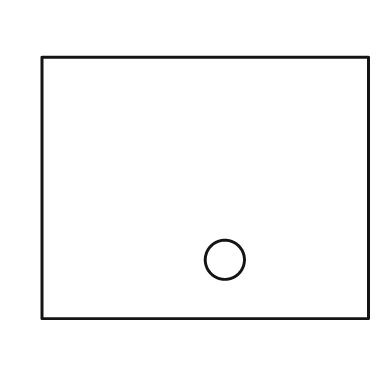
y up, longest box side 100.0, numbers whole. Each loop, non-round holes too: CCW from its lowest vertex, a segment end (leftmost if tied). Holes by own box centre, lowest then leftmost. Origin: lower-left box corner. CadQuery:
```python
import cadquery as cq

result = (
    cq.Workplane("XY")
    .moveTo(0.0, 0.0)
    .lineTo(100.0, 0.0)
    .lineTo(100.0, 80.0)
    .lineTo(0.0, 80.0)
    .close()
    .moveTo(56.0, 18.0)
    .circle(6.0)
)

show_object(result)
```